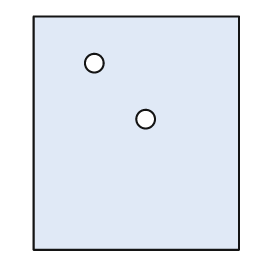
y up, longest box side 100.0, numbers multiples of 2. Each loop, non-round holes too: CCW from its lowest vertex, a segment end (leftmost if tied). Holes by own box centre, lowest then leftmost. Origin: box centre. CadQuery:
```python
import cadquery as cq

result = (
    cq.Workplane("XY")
    .moveTo(-44.0, -50.0)
    .lineTo(44.0, -50.0)
    .lineTo(44.0, 50.0)
    .lineTo(-44.0, 50.0)
    .close()
    .moveTo(4.0, 6.0)
    .circle(4.0)
    .moveTo(-18.0, 30.0)
    .circle(4.0)
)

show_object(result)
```